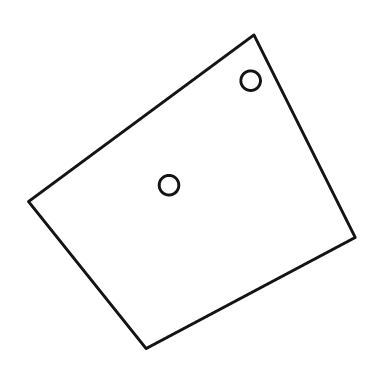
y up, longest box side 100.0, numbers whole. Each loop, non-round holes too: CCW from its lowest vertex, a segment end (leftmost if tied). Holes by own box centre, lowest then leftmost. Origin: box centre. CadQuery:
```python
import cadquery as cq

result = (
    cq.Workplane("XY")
    .moveTo(-14.0, -48.0)
    .lineTo(50.0, -14.0)
    .lineTo(19.0, 48.0)
    .lineTo(-50.0, -3.0)
    .close()
    .moveTo(-7.0, 2.0)
    .circle(3.0)
    .moveTo(18.0, 34.0)
    .circle(3.0)
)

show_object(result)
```